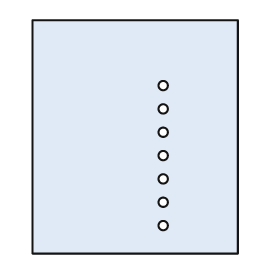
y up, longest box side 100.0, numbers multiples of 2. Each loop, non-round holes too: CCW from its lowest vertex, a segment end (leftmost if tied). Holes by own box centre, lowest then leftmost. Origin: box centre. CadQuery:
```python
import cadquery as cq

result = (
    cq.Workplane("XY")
    .moveTo(-44.0, -50.0)
    .lineTo(44.0, -50.0)
    .lineTo(44.0, 50.0)
    .lineTo(-44.0, 50.0)
    .close()
    .moveTo(12.0, -38.0)
    .circle(2.0)
    .moveTo(12.0, -28.0)
    .circle(2.0)
    .moveTo(12.0, -18.0)
    .circle(2.0)
    .moveTo(12.0, -8.0)
    .circle(2.0)
    .moveTo(12.0, 2.0)
    .circle(2.0)
    .moveTo(12.0, 12.0)
    .circle(2.0)
    .moveTo(12.0, 22.0)
    .circle(2.0)
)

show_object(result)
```